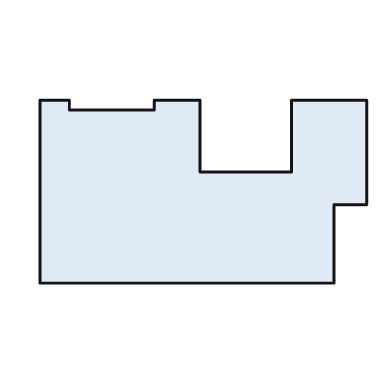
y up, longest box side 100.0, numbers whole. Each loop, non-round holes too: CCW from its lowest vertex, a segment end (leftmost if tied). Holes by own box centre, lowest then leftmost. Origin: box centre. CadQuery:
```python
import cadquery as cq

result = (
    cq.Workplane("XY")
    .moveTo(-50.0, -28.0)
    .lineTo(40.0, -28.0)
    .lineTo(40.0, -4.0)
    .lineTo(50.0, -4.0)
    .lineTo(50.0, 28.0)
    .lineTo(27.0, 28.0)
    .lineTo(27.0, 6.0)
    .lineTo(-1.0, 6.0)
    .lineTo(-1.0, 28.0)
    .lineTo(-15.0, 28.0)
    .lineTo(-15.0, 25.0)
    .lineTo(-41.0, 25.0)
    .lineTo(-41.0, 28.0)
    .lineTo(-50.0, 28.0)
    .close()
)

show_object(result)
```